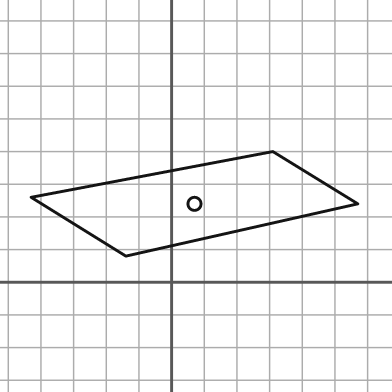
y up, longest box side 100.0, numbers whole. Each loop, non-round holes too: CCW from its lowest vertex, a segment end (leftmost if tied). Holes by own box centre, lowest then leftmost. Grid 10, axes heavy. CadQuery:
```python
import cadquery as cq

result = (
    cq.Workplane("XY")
    .moveTo(-14.0, 8.0)
    .lineTo(57.0, 24.0)
    .lineTo(31.0, 40.0)
    .lineTo(-43.0, 26.0)
    .close()
    .moveTo(7.0, 24.0)
    .circle(2.0)
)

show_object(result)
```